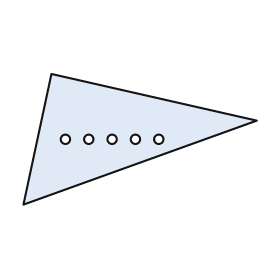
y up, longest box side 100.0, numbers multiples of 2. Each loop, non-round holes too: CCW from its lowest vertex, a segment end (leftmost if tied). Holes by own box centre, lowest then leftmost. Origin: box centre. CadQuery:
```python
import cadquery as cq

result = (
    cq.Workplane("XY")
    .moveTo(-50.0, -28.0)
    .lineTo(50.0, 8.0)
    .lineTo(-38.0, 28.0)
    .close()
    .moveTo(-32.0, 0.0)
    .circle(2.0)
    .moveTo(-22.0, 0.0)
    .circle(2.0)
    .moveTo(-12.0, 0.0)
    .circle(2.0)
    .moveTo(-2.0, 0.0)
    .circle(2.0)
    .moveTo(8.0, 0.0)
    .circle(2.0)
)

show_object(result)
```